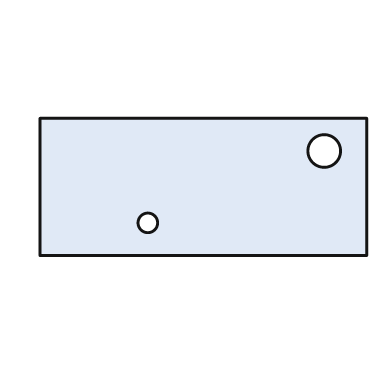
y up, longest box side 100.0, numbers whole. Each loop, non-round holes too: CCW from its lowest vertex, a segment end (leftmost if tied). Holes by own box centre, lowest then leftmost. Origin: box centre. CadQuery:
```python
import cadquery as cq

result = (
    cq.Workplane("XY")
    .moveTo(-50.0, -21.0)
    .lineTo(50.0, -21.0)
    .lineTo(50.0, 21.0)
    .lineTo(-50.0, 21.0)
    .close()
    .moveTo(-17.0, -11.0)
    .circle(3.0)
    .moveTo(37.0, 11.0)
    .circle(5.0)
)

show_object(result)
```